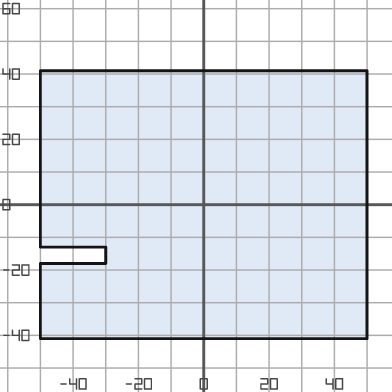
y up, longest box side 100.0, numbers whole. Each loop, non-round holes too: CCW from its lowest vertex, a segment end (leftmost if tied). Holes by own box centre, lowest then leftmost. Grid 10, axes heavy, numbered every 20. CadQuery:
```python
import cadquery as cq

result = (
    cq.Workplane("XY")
    .moveTo(-50.0, -41.0)
    .lineTo(50.0, -41.0)
    .lineTo(50.0, 41.0)
    .lineTo(-50.0, 41.0)
    .lineTo(-50.0, -13.0)
    .lineTo(-30.0, -13.0)
    .lineTo(-30.0, -18.0)
    .lineTo(-50.0, -18.0)
    .close()
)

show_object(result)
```